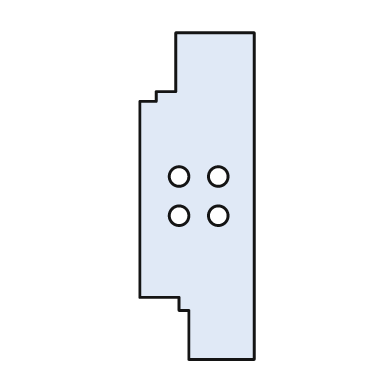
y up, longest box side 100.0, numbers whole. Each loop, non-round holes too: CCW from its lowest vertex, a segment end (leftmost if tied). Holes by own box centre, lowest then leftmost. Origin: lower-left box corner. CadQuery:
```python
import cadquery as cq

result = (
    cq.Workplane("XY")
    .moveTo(15.0, 0.0)
    .lineTo(35.0, 0.0)
    .lineTo(35.0, 100.0)
    .lineTo(11.0, 100.0)
    .lineTo(11.0, 82.0)
    .lineTo(5.0, 82.0)
    .lineTo(5.0, 79.0)
    .lineTo(0.0, 79.0)
    .lineTo(0.0, 19.0)
    .lineTo(12.0, 19.0)
    .lineTo(12.0, 15.0)
    .lineTo(15.0, 15.0)
    .close()
    .moveTo(12.0, 44.0)
    .circle(3.0)
    .moveTo(24.0, 44.0)
    .circle(3.0)
    .moveTo(12.0, 56.0)
    .circle(3.0)
    .moveTo(24.0, 56.0)
    .circle(3.0)
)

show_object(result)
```